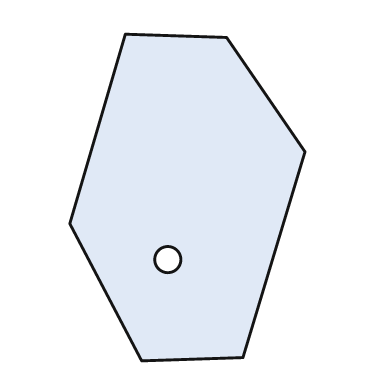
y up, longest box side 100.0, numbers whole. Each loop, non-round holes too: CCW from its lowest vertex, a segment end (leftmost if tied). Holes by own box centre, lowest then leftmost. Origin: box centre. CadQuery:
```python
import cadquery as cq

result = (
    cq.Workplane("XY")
    .moveTo(-14.0, -50.0)
    .lineTo(17.0, -49.0)
    .lineTo(36.0, 14.0)
    .lineTo(12.0, 49.0)
    .lineTo(-19.0, 50.0)
    .lineTo(-36.0, -8.0)
    .close()
    .moveTo(-6.0, -19.0)
    .circle(4.0)
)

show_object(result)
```